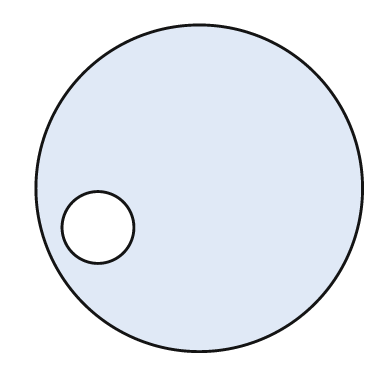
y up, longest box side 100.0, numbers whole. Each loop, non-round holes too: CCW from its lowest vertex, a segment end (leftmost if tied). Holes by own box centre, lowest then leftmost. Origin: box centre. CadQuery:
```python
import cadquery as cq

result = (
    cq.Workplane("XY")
    .moveTo(0.0, 0.0)
    .circle(50.0)
    .moveTo(-31.0, -12.0)
    .circle(11.0)
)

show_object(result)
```